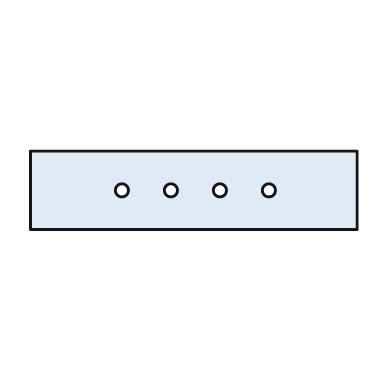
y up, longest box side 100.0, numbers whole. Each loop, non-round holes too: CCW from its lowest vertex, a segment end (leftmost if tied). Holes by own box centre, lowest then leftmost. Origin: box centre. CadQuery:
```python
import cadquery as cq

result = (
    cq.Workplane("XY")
    .moveTo(-50.0, -12.0)
    .lineTo(50.0, -12.0)
    .lineTo(50.0, 12.0)
    .lineTo(-50.0, 12.0)
    .close()
    .moveTo(-22.0, 0.0)
    .circle(2.0)
    .moveTo(-7.0, 0.0)
    .circle(2.0)
    .moveTo(8.0, 0.0)
    .circle(2.0)
    .moveTo(23.0, 0.0)
    .circle(2.0)
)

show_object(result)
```